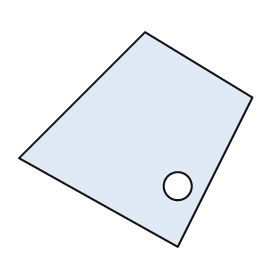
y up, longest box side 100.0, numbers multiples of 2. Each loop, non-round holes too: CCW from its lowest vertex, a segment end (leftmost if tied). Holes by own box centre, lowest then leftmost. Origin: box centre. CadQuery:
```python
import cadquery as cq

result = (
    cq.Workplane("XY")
    .moveTo(18.0, -46.0)
    .lineTo(50.0, 18.0)
    .lineTo(4.0, 46.0)
    .lineTo(-50.0, -8.0)
    .close()
    .moveTo(18.0, -20.0)
    .circle(6.0)
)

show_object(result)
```